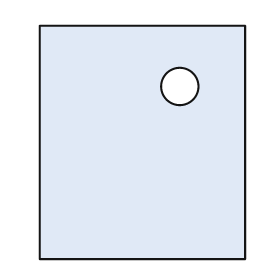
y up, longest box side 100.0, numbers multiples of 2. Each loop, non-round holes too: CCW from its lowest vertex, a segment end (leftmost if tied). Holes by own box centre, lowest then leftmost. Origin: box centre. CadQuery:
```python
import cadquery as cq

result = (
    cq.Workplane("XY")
    .moveTo(-44.0, -50.0)
    .lineTo(44.0, -50.0)
    .lineTo(44.0, 50.0)
    .lineTo(-44.0, 50.0)
    .close()
    .moveTo(16.0, 24.0)
    .circle(8.0)
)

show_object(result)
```